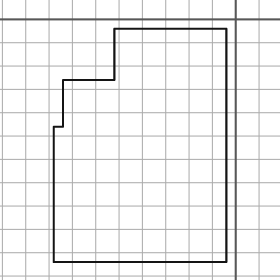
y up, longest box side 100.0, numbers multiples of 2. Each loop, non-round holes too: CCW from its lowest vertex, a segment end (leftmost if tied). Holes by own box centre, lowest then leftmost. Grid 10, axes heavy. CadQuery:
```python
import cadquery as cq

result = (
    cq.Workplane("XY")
    .moveTo(-78.0, -104.0)
    .lineTo(-4.0, -104.0)
    .lineTo(-4.0, -4.0)
    .lineTo(-52.0, -4.0)
    .lineTo(-52.0, -26.0)
    .lineTo(-74.0, -26.0)
    .lineTo(-74.0, -46.0)
    .lineTo(-78.0, -46.0)
    .close()
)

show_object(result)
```